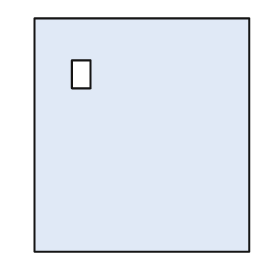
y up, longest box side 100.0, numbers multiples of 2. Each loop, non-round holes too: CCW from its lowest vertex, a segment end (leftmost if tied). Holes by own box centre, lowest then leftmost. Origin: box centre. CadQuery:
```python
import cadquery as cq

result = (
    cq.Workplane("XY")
    .moveTo(-46.0, -50.0)
    .lineTo(46.0, -50.0)
    .lineTo(46.0, 50.0)
    .lineTo(-46.0, 50.0)
    .close()
    .moveTo(-30.0, 20.0)
    .lineTo(-22.0, 20.0)
    .lineTo(-22.0, 32.0)
    .lineTo(-30.0, 32.0)
    .close()
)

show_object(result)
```